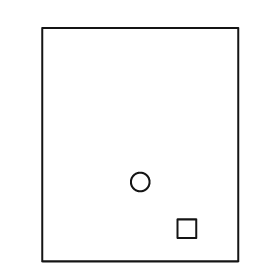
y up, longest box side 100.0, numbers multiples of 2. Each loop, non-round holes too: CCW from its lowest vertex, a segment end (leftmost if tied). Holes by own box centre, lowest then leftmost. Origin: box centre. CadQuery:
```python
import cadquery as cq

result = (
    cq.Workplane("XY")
    .moveTo(-42.0, -50.0)
    .lineTo(42.0, -50.0)
    .lineTo(42.0, 50.0)
    .lineTo(-42.0, 50.0)
    .close()
    .moveTo(16.0, -40.0)
    .lineTo(24.0, -40.0)
    .lineTo(24.0, -32.0)
    .lineTo(16.0, -32.0)
    .close()
    .moveTo(0.0, -16.0)
    .circle(4.0)
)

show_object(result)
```